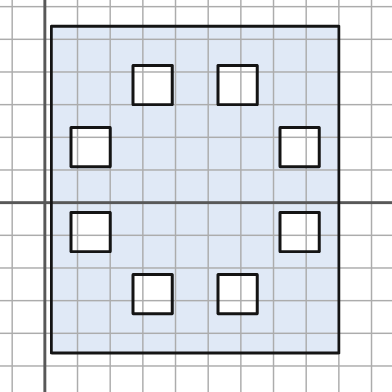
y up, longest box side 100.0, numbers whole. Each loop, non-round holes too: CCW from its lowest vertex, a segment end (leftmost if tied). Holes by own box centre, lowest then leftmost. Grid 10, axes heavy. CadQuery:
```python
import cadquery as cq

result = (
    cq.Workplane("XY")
    .moveTo(2.0, -46.0)
    .lineTo(90.0, -46.0)
    .lineTo(90.0, 54.0)
    .lineTo(2.0, 54.0)
    .close()
    .moveTo(27.0, -34.0)
    .lineTo(39.0, -34.0)
    .lineTo(39.0, -22.0)
    .lineTo(27.0, -22.0)
    .close()
    .moveTo(53.0, -34.0)
    .lineTo(65.0, -34.0)
    .lineTo(65.0, -22.0)
    .lineTo(53.0, -22.0)
    .close()
    .moveTo(8.0, -15.0)
    .lineTo(20.0, -15.0)
    .lineTo(20.0, -3.0)
    .lineTo(8.0, -3.0)
    .close()
    .moveTo(72.0, -15.0)
    .lineTo(84.0, -15.0)
    .lineTo(84.0, -3.0)
    .lineTo(72.0, -3.0)
    .close()
    .moveTo(8.0, 11.0)
    .lineTo(20.0, 11.0)
    .lineTo(20.0, 23.0)
    .lineTo(8.0, 23.0)
    .close()
    .moveTo(72.0, 11.0)
    .lineTo(84.0, 11.0)
    .lineTo(84.0, 23.0)
    .lineTo(72.0, 23.0)
    .close()
    .moveTo(27.0, 30.0)
    .lineTo(39.0, 30.0)
    .lineTo(39.0, 42.0)
    .lineTo(27.0, 42.0)
    .close()
    .moveTo(53.0, 30.0)
    .lineTo(65.0, 30.0)
    .lineTo(65.0, 42.0)
    .lineTo(53.0, 42.0)
    .close()
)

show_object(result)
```